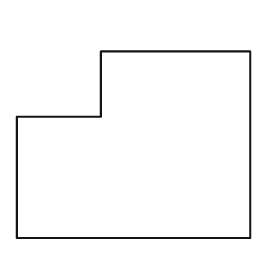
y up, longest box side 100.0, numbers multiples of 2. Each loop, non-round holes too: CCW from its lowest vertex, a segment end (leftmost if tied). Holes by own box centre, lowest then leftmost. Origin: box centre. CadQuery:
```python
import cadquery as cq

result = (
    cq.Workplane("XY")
    .moveTo(-50.0, -40.0)
    .lineTo(50.0, -40.0)
    .lineTo(50.0, 40.0)
    .lineTo(-14.0, 40.0)
    .lineTo(-14.0, 12.0)
    .lineTo(-50.0, 12.0)
    .close()
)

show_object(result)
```